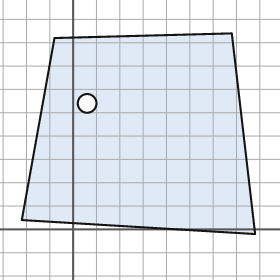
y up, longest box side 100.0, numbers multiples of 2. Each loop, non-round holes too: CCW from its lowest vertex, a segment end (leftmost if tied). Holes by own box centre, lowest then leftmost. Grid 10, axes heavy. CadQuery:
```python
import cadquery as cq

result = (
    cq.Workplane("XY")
    .moveTo(78.0, -2.0)
    .lineTo(68.0, 84.0)
    .lineTo(-8.0, 82.0)
    .lineTo(-22.0, 4.0)
    .close()
    .moveTo(6.0, 54.0)
    .circle(4.0)
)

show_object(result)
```